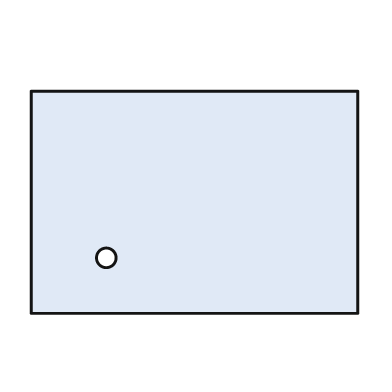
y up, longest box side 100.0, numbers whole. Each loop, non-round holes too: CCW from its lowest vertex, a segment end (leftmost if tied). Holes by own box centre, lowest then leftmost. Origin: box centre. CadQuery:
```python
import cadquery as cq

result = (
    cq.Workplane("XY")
    .moveTo(-50.0, -34.0)
    .lineTo(50.0, -34.0)
    .lineTo(50.0, 34.0)
    .lineTo(-50.0, 34.0)
    .close()
    .moveTo(-27.0, -17.0)
    .circle(3.0)
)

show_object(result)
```